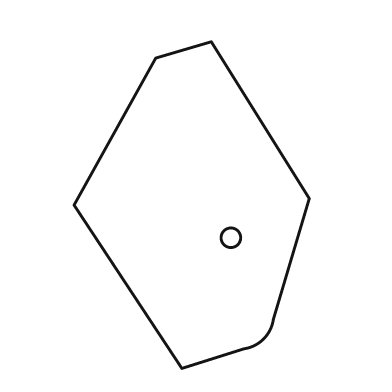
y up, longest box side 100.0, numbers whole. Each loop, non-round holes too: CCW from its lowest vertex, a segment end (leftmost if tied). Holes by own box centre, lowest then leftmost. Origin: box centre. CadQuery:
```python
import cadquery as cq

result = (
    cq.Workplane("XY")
    .moveTo(-3.0, -50.0)
    .lineTo(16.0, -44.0)
    .threePointArc((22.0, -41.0), (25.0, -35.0))
    .lineTo(36.0, 2.0)
    .lineTo(6.0, 50.0)
    .lineTo(-11.0, 45.0)
    .lineTo(-36.0, 0.0)
    .close()
    .moveTo(12.0, -10.0)
    .circle(3.0)
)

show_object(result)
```